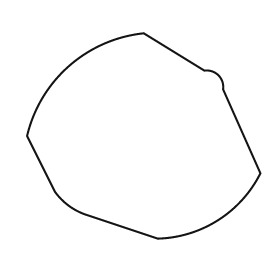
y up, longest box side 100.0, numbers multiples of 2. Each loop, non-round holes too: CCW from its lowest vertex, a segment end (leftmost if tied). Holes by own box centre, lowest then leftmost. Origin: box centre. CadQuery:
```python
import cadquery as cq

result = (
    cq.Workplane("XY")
    .moveTo(6.0, -44.0)
    .threePointArc((32.0, -36.0), (50.0, -16.0))
    .lineTo(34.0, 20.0)
    .threePointArc((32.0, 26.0), (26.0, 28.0))
    .lineTo(0.0, 44.0)
    .threePointArc((-32.0, 30.0), (-50.0, 0.0))
    .lineTo(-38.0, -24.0)
    .threePointArc((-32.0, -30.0), (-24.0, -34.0))
    .close()
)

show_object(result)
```